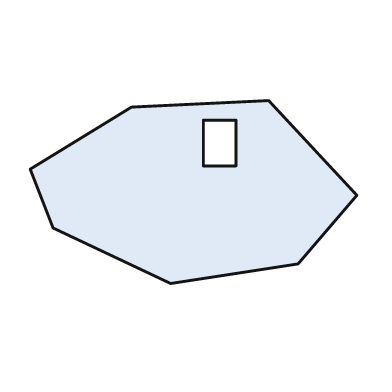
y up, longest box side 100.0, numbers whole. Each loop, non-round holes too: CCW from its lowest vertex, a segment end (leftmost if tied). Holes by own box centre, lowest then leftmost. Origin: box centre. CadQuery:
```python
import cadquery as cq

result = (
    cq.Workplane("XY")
    .moveTo(-7.0, -28.0)
    .lineTo(32.0, -22.0)
    .lineTo(50.0, -1.0)
    .lineTo(23.0, 28.0)
    .lineTo(-19.0, 26.0)
    .lineTo(-50.0, 7.0)
    .lineTo(-43.0, -11.0)
    .close()
    .moveTo(3.0, 8.0)
    .lineTo(13.0, 8.0)
    .lineTo(13.0, 22.0)
    .lineTo(3.0, 22.0)
    .close()
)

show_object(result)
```